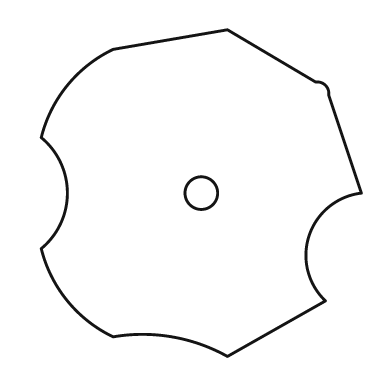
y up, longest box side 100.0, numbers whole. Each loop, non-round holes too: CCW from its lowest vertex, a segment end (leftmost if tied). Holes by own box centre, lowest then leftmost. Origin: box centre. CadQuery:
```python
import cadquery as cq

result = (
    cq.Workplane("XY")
    .moveTo(8.0, -50.0)
    .lineTo(38.0, -33.0)
    .threePointArc((33.0, -13.0), (49.0, 0.0))
    .lineTo(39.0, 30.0)
    .threePointArc((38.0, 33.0), (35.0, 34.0))
    .lineTo(8.0, 50.0)
    .lineTo(-27.0, 44.0)
    .threePointArc((-41.0, 33.0), (-49.0, 17.0))
    .threePointArc((-41.0, 0.0), (-49.0, -17.0))
    .threePointArc((-41.0, -33.0), (-27.0, -44.0))
    .threePointArc((-9.0, -44.0), (8.0, -50.0))
    .close()
    .moveTo(0.0, 0.0)
    .circle(5.0)
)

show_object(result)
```